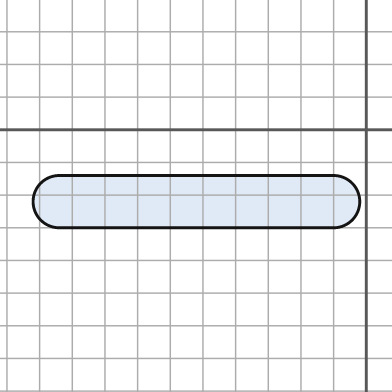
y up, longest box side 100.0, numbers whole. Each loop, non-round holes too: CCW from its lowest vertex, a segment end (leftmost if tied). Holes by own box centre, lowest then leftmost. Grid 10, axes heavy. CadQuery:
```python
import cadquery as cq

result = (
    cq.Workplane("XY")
    .moveTo(-94.0, -30.0)
    .lineTo(-10.0, -30.0)
    .threePointArc((-2.0, -22.0), (-10.0, -14.0))
    .lineTo(-94.0, -14.0)
    .threePointArc((-102.0, -22.0), (-94.0, -30.0))
    .close()
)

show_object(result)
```